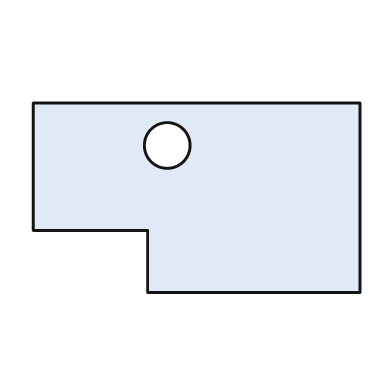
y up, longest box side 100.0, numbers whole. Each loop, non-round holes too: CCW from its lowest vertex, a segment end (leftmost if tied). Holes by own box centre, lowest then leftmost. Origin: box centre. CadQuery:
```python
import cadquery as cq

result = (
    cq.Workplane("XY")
    .moveTo(-15.0, -29.0)
    .lineTo(50.0, -29.0)
    .lineTo(50.0, 29.0)
    .lineTo(-50.0, 29.0)
    .lineTo(-50.0, -10.0)
    .lineTo(-15.0, -10.0)
    .close()
    .moveTo(-9.0, 16.0)
    .circle(7.0)
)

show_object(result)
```